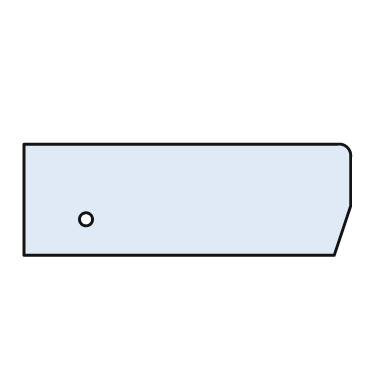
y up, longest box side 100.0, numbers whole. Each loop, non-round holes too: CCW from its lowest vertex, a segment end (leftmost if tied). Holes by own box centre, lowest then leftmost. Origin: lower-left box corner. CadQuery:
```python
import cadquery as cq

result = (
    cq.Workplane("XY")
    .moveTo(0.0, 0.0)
    .lineTo(95.0, 0.0)
    .lineTo(100.0, 15.0)
    .lineTo(100.0, 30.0)
    .threePointArc((99.0, 33.0), (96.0, 34.0))
    .lineTo(0.0, 34.0)
    .close()
    .moveTo(19.0, 11.0)
    .circle(2.0)
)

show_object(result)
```